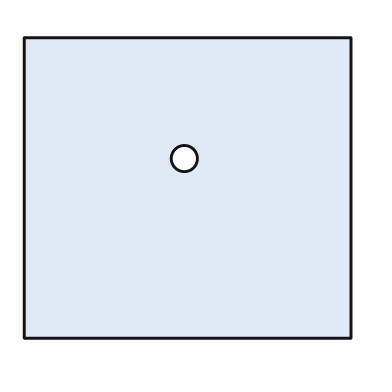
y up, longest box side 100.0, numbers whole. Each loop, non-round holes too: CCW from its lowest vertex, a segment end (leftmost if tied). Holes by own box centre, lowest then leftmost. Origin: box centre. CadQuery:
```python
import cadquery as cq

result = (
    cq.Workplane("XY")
    .moveTo(-50.0, -46.0)
    .lineTo(50.0, -46.0)
    .lineTo(50.0, 46.0)
    .lineTo(-50.0, 46.0)
    .close()
    .moveTo(-1.0, 9.0)
    .circle(4.0)
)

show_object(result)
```